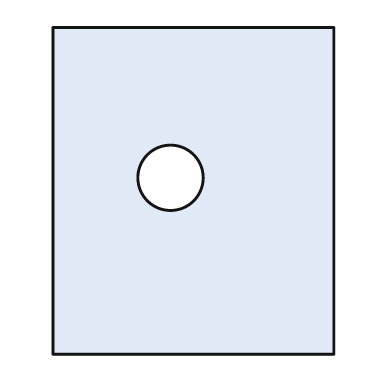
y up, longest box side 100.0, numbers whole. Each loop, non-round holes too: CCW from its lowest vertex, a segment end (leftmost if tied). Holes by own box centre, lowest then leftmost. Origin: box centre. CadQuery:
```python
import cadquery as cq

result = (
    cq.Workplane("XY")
    .moveTo(-43.0, -50.0)
    .lineTo(43.0, -50.0)
    .lineTo(43.0, 50.0)
    .lineTo(-43.0, 50.0)
    .close()
    .moveTo(-7.0, 4.0)
    .circle(10.0)
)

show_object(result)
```